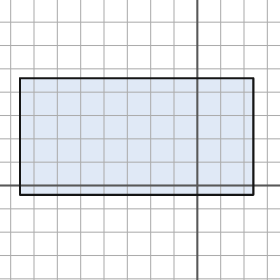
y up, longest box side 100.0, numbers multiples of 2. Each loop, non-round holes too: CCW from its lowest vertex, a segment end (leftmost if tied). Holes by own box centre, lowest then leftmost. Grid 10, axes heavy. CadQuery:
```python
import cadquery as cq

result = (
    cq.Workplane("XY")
    .moveTo(-76.0, -4.0)
    .lineTo(24.0, -4.0)
    .lineTo(24.0, 46.0)
    .lineTo(-76.0, 46.0)
    .close()
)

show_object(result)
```